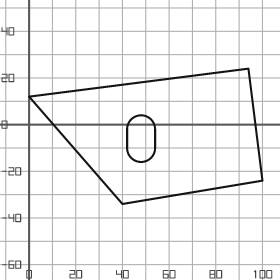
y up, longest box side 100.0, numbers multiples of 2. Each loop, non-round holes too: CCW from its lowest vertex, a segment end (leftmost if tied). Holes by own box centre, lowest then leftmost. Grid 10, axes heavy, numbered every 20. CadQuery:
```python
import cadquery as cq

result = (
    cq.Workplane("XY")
    .moveTo(40.0, -34.0)
    .lineTo(100.0, -24.0)
    .lineTo(94.0, 24.0)
    .lineTo(0.0, 12.0)
    .close()
    .moveTo(42.0, -10.0)
    .threePointArc((48.0, -16.0), (54.0, -10.0))
    .lineTo(54.0, -2.0)
    .threePointArc((48.0, 4.0), (42.0, -2.0))
    .close()
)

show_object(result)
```